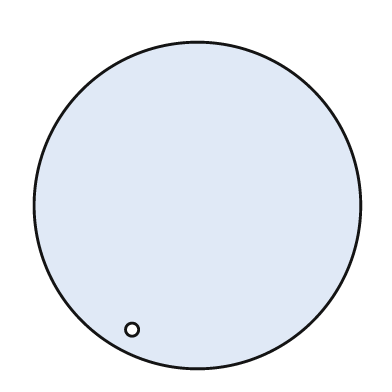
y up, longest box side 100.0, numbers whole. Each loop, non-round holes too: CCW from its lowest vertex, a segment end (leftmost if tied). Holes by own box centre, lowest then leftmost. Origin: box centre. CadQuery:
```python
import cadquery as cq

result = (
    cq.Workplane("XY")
    .moveTo(0.0, 0.0)
    .circle(50.0)
    .moveTo(-20.0, -38.0)
    .circle(2.0)
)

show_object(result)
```